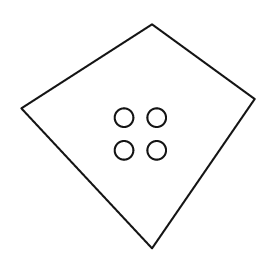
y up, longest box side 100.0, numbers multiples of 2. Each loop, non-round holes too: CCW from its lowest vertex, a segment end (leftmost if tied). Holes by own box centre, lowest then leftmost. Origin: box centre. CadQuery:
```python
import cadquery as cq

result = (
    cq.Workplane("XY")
    .moveTo(6.0, -48.0)
    .lineTo(50.0, 16.0)
    .lineTo(6.0, 48.0)
    .lineTo(-50.0, 12.0)
    .close()
    .moveTo(-6.0, -6.0)
    .circle(4.0)
    .moveTo(8.0, -6.0)
    .circle(4.0)
    .moveTo(-6.0, 8.0)
    .circle(4.0)
    .moveTo(8.0, 8.0)
    .circle(4.0)
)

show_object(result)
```